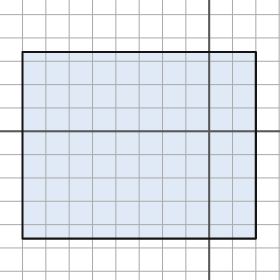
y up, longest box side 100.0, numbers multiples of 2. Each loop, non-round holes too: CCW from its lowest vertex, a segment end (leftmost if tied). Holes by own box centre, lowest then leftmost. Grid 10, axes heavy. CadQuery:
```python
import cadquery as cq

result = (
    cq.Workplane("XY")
    .moveTo(-80.0, -46.0)
    .lineTo(20.0, -46.0)
    .lineTo(20.0, 34.0)
    .lineTo(-80.0, 34.0)
    .close()
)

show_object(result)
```